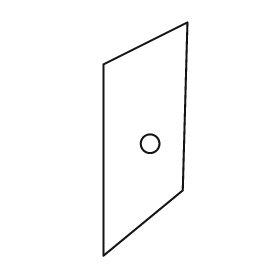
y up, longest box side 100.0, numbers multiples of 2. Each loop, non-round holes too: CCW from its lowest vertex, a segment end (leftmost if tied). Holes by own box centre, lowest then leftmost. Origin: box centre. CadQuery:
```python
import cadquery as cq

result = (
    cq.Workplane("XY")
    .moveTo(-18.0, -50.0)
    .lineTo(16.0, -22.0)
    .lineTo(18.0, 50.0)
    .lineTo(-18.0, 32.0)
    .close()
    .moveTo(2.0, -2.0)
    .circle(4.0)
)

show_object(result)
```